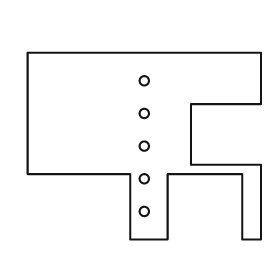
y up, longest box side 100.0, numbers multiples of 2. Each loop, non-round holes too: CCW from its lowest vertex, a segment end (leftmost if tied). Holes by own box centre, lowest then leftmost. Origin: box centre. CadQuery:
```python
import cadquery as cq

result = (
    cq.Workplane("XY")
    .moveTo(-6.0, -40.0)
    .lineTo(10.0, -40.0)
    .lineTo(10.0, -12.0)
    .lineTo(42.0, -12.0)
    .lineTo(42.0, -40.0)
    .lineTo(50.0, -40.0)
    .lineTo(50.0, -8.0)
    .lineTo(20.0, -8.0)
    .lineTo(20.0, 18.0)
    .lineTo(50.0, 18.0)
    .lineTo(50.0, 40.0)
    .lineTo(-50.0, 40.0)
    .lineTo(-50.0, -12.0)
    .lineTo(-6.0, -12.0)
    .close()
    .moveTo(0.0, -28.0)
    .circle(2.0)
    .moveTo(0.0, -14.0)
    .circle(2.0)
    .moveTo(0.0, 0.0)
    .circle(2.0)
    .moveTo(0.0, 14.0)
    .circle(2.0)
    .moveTo(0.0, 28.0)
    .circle(2.0)
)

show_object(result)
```